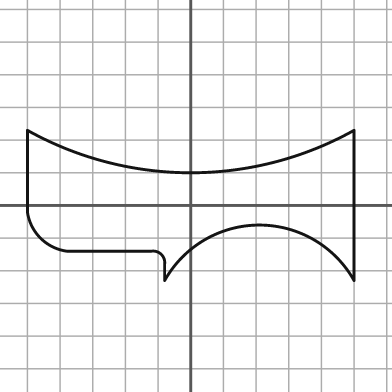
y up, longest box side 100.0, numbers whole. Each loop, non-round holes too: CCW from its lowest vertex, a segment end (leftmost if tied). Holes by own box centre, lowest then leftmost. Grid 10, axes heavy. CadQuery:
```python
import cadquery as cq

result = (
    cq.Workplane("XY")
    .moveTo(-8.0, -23.0)
    .threePointArc((21.0, -6.0), (50.0, -23.0))
    .lineTo(50.0, 23.0)
    .threePointArc((0.0, 10.0), (-50.0, 23.0))
    .lineTo(-50.0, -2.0)
    .threePointArc((-46.0, -10.0), (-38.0, -14.0))
    .lineTo(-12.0, -14.0)
    .threePointArc((-9.0, -15.0), (-8.0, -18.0))
    .close()
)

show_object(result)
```